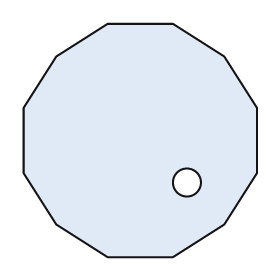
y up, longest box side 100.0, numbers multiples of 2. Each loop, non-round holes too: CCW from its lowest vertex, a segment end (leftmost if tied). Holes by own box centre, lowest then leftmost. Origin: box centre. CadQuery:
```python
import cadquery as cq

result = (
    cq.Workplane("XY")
    .moveTo(-14.0, -50.0)
    .lineTo(14.0, -50.0)
    .lineTo(36.0, -36.0)
    .lineTo(50.0, -14.0)
    .lineTo(50.0, 14.0)
    .lineTo(36.0, 36.0)
    .lineTo(14.0, 50.0)
    .lineTo(-14.0, 50.0)
    .lineTo(-36.0, 36.0)
    .lineTo(-50.0, 14.0)
    .lineTo(-50.0, -14.0)
    .lineTo(-36.0, -36.0)
    .close()
    .moveTo(20.0, -18.0)
    .circle(6.0)
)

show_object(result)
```